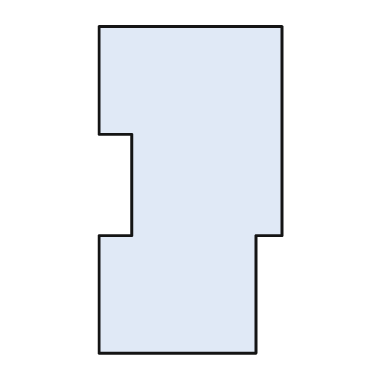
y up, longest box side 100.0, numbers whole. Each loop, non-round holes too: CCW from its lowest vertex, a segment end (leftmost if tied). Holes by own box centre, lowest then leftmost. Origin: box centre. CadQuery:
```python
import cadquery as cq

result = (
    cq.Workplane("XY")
    .moveTo(-28.0, -50.0)
    .lineTo(20.0, -50.0)
    .lineTo(20.0, -14.0)
    .lineTo(28.0, -14.0)
    .lineTo(28.0, 50.0)
    .lineTo(-28.0, 50.0)
    .lineTo(-28.0, 17.0)
    .lineTo(-18.0, 17.0)
    .lineTo(-18.0, -14.0)
    .lineTo(-28.0, -14.0)
    .close()
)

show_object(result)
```